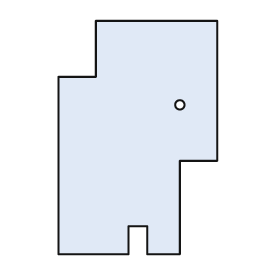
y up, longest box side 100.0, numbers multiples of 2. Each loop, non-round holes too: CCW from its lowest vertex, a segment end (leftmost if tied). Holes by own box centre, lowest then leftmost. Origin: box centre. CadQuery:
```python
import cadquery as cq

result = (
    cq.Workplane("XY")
    .moveTo(-34.0, -50.0)
    .lineTo(-4.0, -50.0)
    .lineTo(-4.0, -38.0)
    .lineTo(4.0, -38.0)
    .lineTo(4.0, -50.0)
    .lineTo(18.0, -50.0)
    .lineTo(18.0, -10.0)
    .lineTo(34.0, -10.0)
    .lineTo(34.0, 50.0)
    .lineTo(-18.0, 50.0)
    .lineTo(-18.0, 26.0)
    .lineTo(-34.0, 26.0)
    .close()
    .moveTo(18.0, 14.0)
    .circle(2.0)
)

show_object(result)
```